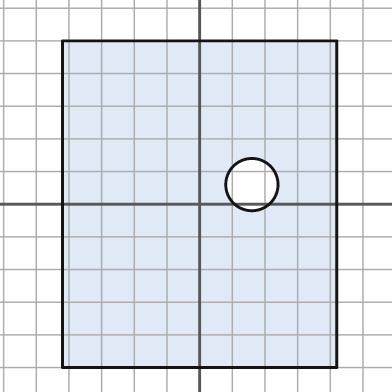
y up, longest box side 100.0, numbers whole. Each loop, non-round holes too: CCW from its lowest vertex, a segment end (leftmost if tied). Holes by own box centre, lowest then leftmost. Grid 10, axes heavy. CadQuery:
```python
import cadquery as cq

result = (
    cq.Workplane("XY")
    .moveTo(-42.0, -50.0)
    .lineTo(42.0, -50.0)
    .lineTo(42.0, 50.0)
    .lineTo(-42.0, 50.0)
    .close()
    .moveTo(16.0, 6.0)
    .circle(8.0)
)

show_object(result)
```